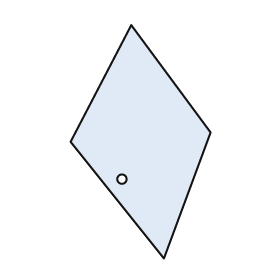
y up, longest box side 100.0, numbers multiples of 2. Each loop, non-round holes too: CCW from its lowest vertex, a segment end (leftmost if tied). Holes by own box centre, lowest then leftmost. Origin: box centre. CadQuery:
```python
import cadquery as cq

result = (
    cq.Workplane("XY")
    .moveTo(10.0, -50.0)
    .lineTo(30.0, 4.0)
    .lineTo(-4.0, 50.0)
    .lineTo(-30.0, 0.0)
    .close()
    .moveTo(-8.0, -16.0)
    .circle(2.0)
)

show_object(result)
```